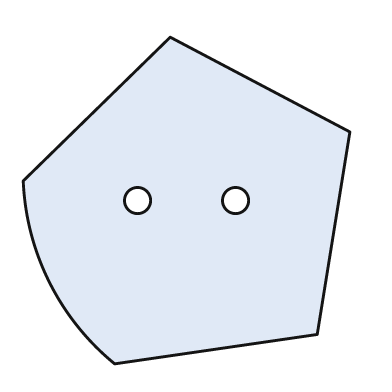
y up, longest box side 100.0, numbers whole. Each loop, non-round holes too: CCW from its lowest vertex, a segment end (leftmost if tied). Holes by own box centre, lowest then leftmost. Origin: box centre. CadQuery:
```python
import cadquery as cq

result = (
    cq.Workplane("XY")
    .moveTo(-22.0, -50.0)
    .lineTo(40.0, -41.0)
    .lineTo(50.0, 21.0)
    .lineTo(-5.0, 50.0)
    .lineTo(-50.0, 6.0)
    .threePointArc((-42.0, -25.0), (-22.0, -50.0))
    .close()
    .moveTo(-15.0, 0.0)
    .circle(4.0)
    .moveTo(15.0, 0.0)
    .circle(4.0)
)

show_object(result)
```